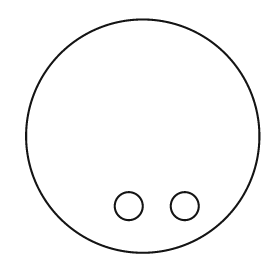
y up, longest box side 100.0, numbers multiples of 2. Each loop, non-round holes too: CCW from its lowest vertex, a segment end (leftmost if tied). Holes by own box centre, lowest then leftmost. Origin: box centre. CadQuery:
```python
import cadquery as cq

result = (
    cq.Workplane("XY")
    .moveTo(0.0, 0.0)
    .circle(50.0)
    .moveTo(-6.0, -30.0)
    .circle(6.0)
    .moveTo(18.0, -30.0)
    .circle(6.0)
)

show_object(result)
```